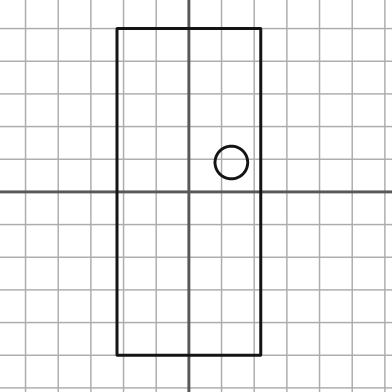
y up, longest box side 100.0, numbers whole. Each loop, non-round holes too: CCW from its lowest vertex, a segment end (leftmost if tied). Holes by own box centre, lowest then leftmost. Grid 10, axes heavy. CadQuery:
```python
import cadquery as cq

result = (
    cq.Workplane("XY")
    .moveTo(-22.0, -50.0)
    .lineTo(22.0, -50.0)
    .lineTo(22.0, 50.0)
    .lineTo(-22.0, 50.0)
    .close()
    .moveTo(13.0, 9.0)
    .circle(5.0)
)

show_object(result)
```